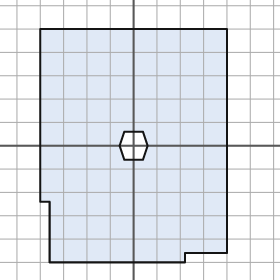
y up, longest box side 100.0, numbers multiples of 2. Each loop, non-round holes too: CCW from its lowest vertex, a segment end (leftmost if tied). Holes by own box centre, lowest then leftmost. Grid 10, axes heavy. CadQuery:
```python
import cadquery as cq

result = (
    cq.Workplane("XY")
    .moveTo(-36.0, -50.0)
    .lineTo(22.0, -50.0)
    .lineTo(22.0, -46.0)
    .lineTo(40.0, -46.0)
    .lineTo(40.0, 50.0)
    .lineTo(-40.0, 50.0)
    .lineTo(-40.0, -24.0)
    .lineTo(-36.0, -24.0)
    .close()
    .moveTo(-4.0, -6.0)
    .lineTo(4.0, -6.0)
    .lineTo(6.0, 0.0)
    .lineTo(4.0, 6.0)
    .lineTo(-4.0, 6.0)
    .lineTo(-6.0, 0.0)
    .close()
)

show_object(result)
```